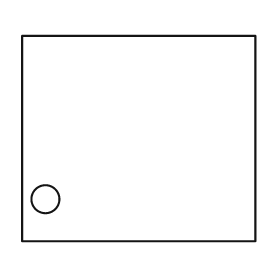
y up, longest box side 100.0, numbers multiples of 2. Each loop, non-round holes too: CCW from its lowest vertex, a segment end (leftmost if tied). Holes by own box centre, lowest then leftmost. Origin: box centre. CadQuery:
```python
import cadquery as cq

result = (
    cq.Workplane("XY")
    .moveTo(-50.0, -44.0)
    .lineTo(50.0, -44.0)
    .lineTo(50.0, 44.0)
    .lineTo(-50.0, 44.0)
    .close()
    .moveTo(-40.0, -26.0)
    .circle(6.0)
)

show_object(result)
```